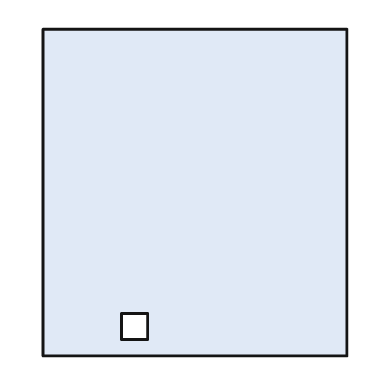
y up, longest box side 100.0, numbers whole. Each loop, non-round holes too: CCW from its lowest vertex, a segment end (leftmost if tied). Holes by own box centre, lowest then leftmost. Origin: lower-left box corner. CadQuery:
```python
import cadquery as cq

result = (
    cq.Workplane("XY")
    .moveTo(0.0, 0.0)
    .lineTo(93.0, 0.0)
    .lineTo(93.0, 100.0)
    .lineTo(0.0, 100.0)
    .close()
    .moveTo(24.0, 5.0)
    .lineTo(32.0, 5.0)
    .lineTo(32.0, 13.0)
    .lineTo(24.0, 13.0)
    .close()
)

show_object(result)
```